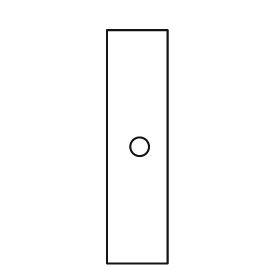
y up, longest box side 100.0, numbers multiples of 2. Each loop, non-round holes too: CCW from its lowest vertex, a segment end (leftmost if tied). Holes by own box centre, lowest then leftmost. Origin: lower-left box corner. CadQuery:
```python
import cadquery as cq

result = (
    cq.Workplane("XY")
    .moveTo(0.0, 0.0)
    .lineTo(26.0, 0.0)
    .lineTo(26.0, 100.0)
    .lineTo(0.0, 100.0)
    .close()
    .moveTo(14.0, 50.0)
    .circle(4.0)
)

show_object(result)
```